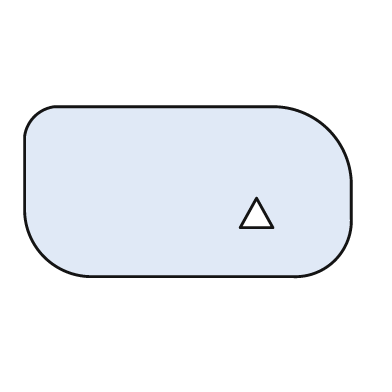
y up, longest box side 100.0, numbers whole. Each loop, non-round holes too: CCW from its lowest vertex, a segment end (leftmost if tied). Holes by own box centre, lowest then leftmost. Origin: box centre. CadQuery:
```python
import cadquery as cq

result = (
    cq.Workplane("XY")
    .moveTo(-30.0, -26.0)
    .lineTo(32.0, -26.0)
    .threePointArc((45.0, -21.0), (50.0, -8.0))
    .lineTo(50.0, 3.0)
    .threePointArc((43.0, 19.0), (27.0, 26.0))
    .lineTo(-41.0, 26.0)
    .threePointArc((-47.0, 23.0), (-50.0, 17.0))
    .lineTo(-50.0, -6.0)
    .threePointArc((-44.0, -20.0), (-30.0, -26.0))
    .close()
    .moveTo(16.0, -11.0)
    .lineTo(26.0, -11.0)
    .lineTo(21.0, -2.0)
    .close()
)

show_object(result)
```